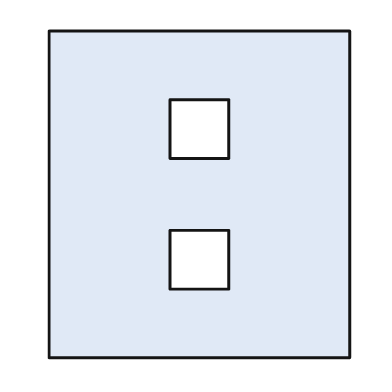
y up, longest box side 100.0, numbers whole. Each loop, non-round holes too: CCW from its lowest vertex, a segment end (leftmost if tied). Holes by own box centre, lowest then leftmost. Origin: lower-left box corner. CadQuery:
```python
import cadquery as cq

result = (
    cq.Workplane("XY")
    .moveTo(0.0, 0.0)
    .lineTo(92.0, 0.0)
    .lineTo(92.0, 100.0)
    .lineTo(0.0, 100.0)
    .close()
    .moveTo(37.0, 21.0)
    .lineTo(55.0, 21.0)
    .lineTo(55.0, 39.0)
    .lineTo(37.0, 39.0)
    .close()
    .moveTo(37.0, 61.0)
    .lineTo(55.0, 61.0)
    .lineTo(55.0, 79.0)
    .lineTo(37.0, 79.0)
    .close()
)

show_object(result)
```